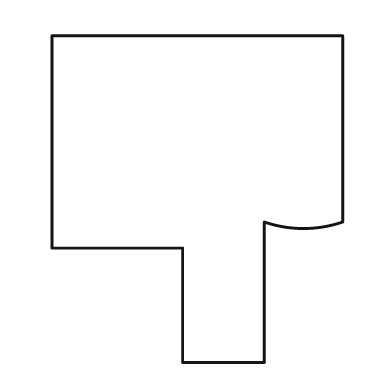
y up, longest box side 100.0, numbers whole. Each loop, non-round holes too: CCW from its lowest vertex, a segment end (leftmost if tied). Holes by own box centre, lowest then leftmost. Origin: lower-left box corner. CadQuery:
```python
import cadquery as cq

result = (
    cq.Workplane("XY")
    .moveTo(40.0, 0.0)
    .lineTo(65.0, 0.0)
    .lineTo(65.0, 43.0)
    .threePointArc((77.0, 41.0), (89.0, 43.0))
    .lineTo(89.0, 100.0)
    .lineTo(0.0, 100.0)
    .lineTo(0.0, 35.0)
    .lineTo(40.0, 35.0)
    .close()
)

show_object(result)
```